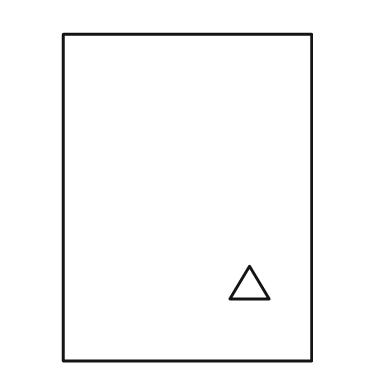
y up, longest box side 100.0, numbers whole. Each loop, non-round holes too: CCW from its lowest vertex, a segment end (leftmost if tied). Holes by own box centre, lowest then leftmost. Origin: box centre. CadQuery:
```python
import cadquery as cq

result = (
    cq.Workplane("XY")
    .moveTo(-38.0, -50.0)
    .lineTo(38.0, -50.0)
    .lineTo(38.0, 50.0)
    .lineTo(-38.0, 50.0)
    .close()
    .moveTo(13.0, -31.0)
    .lineTo(25.0, -31.0)
    .lineTo(19.0, -21.0)
    .close()
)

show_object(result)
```